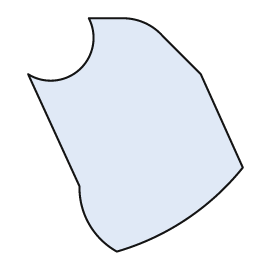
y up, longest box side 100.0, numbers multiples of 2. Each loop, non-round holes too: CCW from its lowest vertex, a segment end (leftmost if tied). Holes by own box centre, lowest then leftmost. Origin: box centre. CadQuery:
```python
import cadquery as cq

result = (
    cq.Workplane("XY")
    .moveTo(-8.0, -50.0)
    .threePointArc((22.0, -36.0), (46.0, -14.0))
    .lineTo(28.0, 26.0)
    .lineTo(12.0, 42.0)
    .threePointArc((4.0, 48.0), (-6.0, 50.0))
    .lineTo(-20.0, 50.0)
    .threePointArc((-24.0, 28.0), (-46.0, 26.0))
    .lineTo(-24.0, -22.0)
    .threePointArc((-20.0, -38.0), (-8.0, -50.0))
    .close()
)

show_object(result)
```